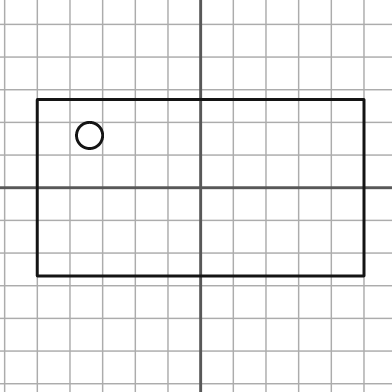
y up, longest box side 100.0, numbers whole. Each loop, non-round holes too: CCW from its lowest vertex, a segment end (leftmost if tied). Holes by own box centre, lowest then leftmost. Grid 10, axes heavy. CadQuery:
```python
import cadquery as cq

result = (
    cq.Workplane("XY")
    .moveTo(-50.0, -27.0)
    .lineTo(50.0, -27.0)
    .lineTo(50.0, 27.0)
    .lineTo(-50.0, 27.0)
    .close()
    .moveTo(-34.0, 16.0)
    .circle(4.0)
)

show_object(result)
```